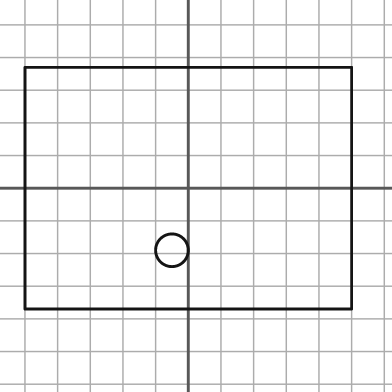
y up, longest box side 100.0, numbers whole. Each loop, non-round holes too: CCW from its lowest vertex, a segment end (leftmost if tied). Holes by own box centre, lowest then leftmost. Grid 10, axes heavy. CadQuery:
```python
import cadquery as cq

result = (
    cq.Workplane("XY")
    .moveTo(-50.0, -37.0)
    .lineTo(50.0, -37.0)
    .lineTo(50.0, 37.0)
    .lineTo(-50.0, 37.0)
    .close()
    .moveTo(-5.0, -19.0)
    .circle(5.0)
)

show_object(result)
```